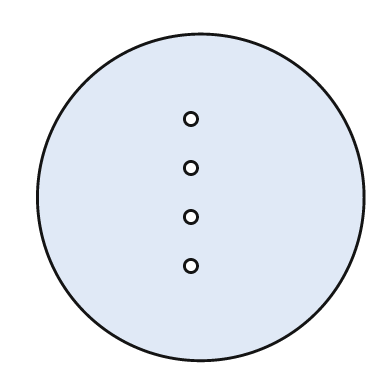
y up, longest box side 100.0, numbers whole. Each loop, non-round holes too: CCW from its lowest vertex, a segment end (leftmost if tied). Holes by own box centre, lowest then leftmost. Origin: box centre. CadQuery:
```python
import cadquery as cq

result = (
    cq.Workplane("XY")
    .moveTo(0.0, 0.0)
    .circle(50.0)
    .moveTo(-3.0, -21.0)
    .circle(2.0)
    .moveTo(-3.0, -6.0)
    .circle(2.0)
    .moveTo(-3.0, 9.0)
    .circle(2.0)
    .moveTo(-3.0, 24.0)
    .circle(2.0)
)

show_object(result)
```